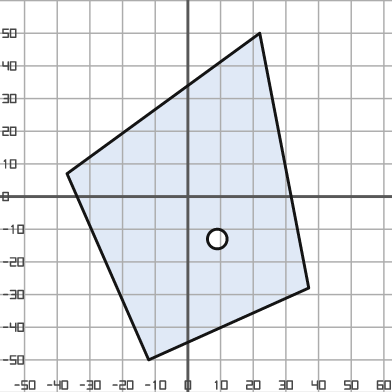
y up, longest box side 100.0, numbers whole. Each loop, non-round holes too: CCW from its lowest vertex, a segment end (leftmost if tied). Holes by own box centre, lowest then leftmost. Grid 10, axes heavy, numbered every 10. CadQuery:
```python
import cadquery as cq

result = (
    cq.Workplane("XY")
    .moveTo(-12.0, -50.0)
    .lineTo(37.0, -28.0)
    .lineTo(22.0, 50.0)
    .lineTo(-37.0, 7.0)
    .close()
    .moveTo(9.0, -13.0)
    .circle(3.0)
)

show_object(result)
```